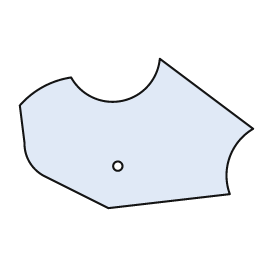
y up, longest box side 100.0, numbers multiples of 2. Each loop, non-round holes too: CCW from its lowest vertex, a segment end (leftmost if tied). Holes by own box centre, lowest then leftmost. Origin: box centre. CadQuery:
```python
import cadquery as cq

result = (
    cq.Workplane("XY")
    .moveTo(-12.0, -32.0)
    .lineTo(40.0, -26.0)
    .threePointArc((40.0, -10.0), (50.0, 2.0))
    .lineTo(10.0, 32.0)
    .threePointArc((-6.0, 14.0), (-28.0, 24.0))
    .threePointArc((-40.0, 20.0), (-50.0, 12.0))
    .lineTo(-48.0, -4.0)
    .threePointArc((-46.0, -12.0), (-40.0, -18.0))
    .close()
    .moveTo(-8.0, -14.0)
    .circle(2.0)
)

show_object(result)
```